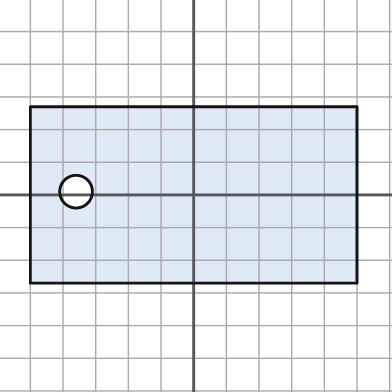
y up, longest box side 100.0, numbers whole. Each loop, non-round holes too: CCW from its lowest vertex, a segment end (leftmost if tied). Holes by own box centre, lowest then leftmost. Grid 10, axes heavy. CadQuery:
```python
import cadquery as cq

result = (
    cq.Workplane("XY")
    .moveTo(-50.0, -27.0)
    .lineTo(50.0, -27.0)
    .lineTo(50.0, 27.0)
    .lineTo(-50.0, 27.0)
    .close()
    .moveTo(-36.0, 1.0)
    .circle(5.0)
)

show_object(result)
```